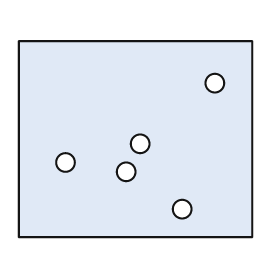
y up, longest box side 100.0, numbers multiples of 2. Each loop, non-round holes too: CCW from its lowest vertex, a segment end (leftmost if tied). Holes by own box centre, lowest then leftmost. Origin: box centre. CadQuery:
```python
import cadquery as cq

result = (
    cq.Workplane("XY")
    .moveTo(-50.0, -42.0)
    .lineTo(50.0, -42.0)
    .lineTo(50.0, 42.0)
    .lineTo(-50.0, 42.0)
    .close()
    .moveTo(20.0, -30.0)
    .circle(4.0)
    .moveTo(-4.0, -14.0)
    .circle(4.0)
    .moveTo(-30.0, -10.0)
    .circle(4.0)
    .moveTo(2.0, -2.0)
    .circle(4.0)
    .moveTo(34.0, 24.0)
    .circle(4.0)
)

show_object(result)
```